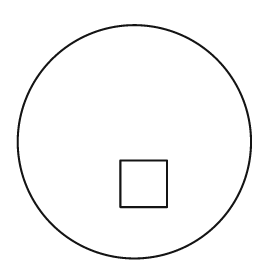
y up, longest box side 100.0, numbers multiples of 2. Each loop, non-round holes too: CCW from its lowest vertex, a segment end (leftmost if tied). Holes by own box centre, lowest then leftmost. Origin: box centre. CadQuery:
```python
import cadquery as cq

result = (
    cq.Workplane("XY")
    .moveTo(0.0, 0.0)
    .circle(50.0)
    .moveTo(-6.0, -28.0)
    .lineTo(14.0, -28.0)
    .lineTo(14.0, -8.0)
    .lineTo(-6.0, -8.0)
    .close()
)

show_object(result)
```